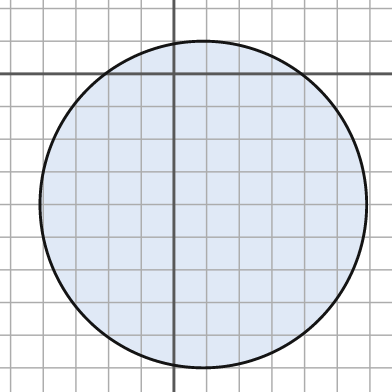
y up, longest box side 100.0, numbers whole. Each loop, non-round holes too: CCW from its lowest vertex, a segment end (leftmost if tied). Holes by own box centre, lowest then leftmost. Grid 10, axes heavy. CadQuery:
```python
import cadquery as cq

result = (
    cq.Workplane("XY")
    .moveTo(9.0, -40.0)
    .circle(50.0)
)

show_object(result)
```